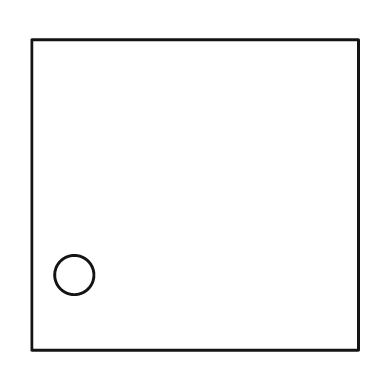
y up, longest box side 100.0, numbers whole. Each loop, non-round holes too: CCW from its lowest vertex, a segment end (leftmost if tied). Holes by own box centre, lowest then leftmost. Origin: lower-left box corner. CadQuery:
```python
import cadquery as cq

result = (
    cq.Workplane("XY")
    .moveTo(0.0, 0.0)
    .lineTo(100.0, 0.0)
    .lineTo(100.0, 95.0)
    .lineTo(0.0, 95.0)
    .close()
    .moveTo(13.0, 23.0)
    .circle(6.0)
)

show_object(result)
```